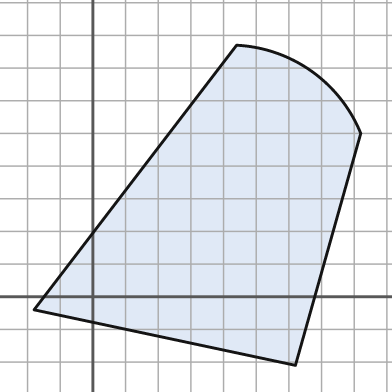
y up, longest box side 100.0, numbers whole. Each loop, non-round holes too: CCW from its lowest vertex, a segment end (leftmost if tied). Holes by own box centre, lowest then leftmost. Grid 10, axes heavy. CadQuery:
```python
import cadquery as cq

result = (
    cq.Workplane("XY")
    .moveTo(62.0, -21.0)
    .lineTo(82.0, 50.0)
    .threePointArc((67.0, 69.0), (44.0, 77.0))
    .lineTo(-18.0, -4.0)
    .close()
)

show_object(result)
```